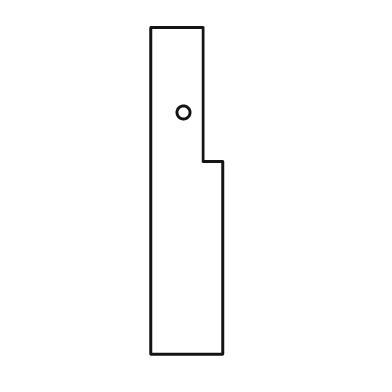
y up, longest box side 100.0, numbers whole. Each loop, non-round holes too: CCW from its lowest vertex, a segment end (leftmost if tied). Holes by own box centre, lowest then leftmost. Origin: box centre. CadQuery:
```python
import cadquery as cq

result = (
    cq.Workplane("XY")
    .moveTo(-11.0, -50.0)
    .lineTo(11.0, -50.0)
    .lineTo(11.0, 9.0)
    .lineTo(5.0, 9.0)
    .lineTo(5.0, 50.0)
    .lineTo(-11.0, 50.0)
    .close()
    .moveTo(-1.0, 24.0)
    .circle(2.0)
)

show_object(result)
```